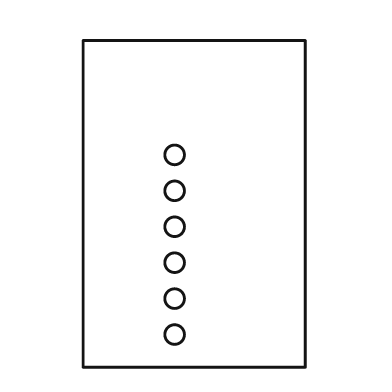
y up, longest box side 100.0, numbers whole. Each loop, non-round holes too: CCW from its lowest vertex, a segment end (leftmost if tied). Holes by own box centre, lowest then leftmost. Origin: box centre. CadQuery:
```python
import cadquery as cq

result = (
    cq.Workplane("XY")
    .moveTo(-34.0, -50.0)
    .lineTo(34.0, -50.0)
    .lineTo(34.0, 50.0)
    .lineTo(-34.0, 50.0)
    .close()
    .moveTo(-6.0, -40.0)
    .circle(3.0)
    .moveTo(-6.0, -29.0)
    .circle(3.0)
    .moveTo(-6.0, -18.0)
    .circle(3.0)
    .moveTo(-6.0, -7.0)
    .circle(3.0)
    .moveTo(-6.0, 4.0)
    .circle(3.0)
    .moveTo(-6.0, 15.0)
    .circle(3.0)
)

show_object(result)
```